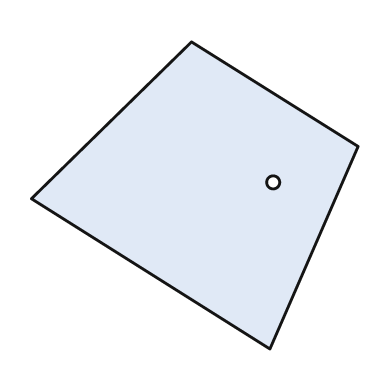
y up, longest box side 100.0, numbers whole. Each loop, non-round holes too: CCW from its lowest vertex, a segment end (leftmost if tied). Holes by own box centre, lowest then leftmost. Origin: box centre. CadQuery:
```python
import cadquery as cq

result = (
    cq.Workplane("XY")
    .moveTo(23.0, -47.0)
    .lineTo(50.0, 15.0)
    .lineTo(-1.0, 47.0)
    .lineTo(-50.0, -1.0)
    .close()
    .moveTo(24.0, 4.0)
    .circle(2.0)
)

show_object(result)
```